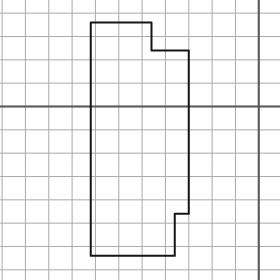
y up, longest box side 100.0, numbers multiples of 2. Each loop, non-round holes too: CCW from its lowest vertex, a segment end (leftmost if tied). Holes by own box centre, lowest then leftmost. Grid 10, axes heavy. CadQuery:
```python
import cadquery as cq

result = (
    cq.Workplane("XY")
    .moveTo(-72.0, -64.0)
    .lineTo(-36.0, -64.0)
    .lineTo(-36.0, -46.0)
    .lineTo(-30.0, -46.0)
    .lineTo(-30.0, 24.0)
    .lineTo(-46.0, 24.0)
    .lineTo(-46.0, 36.0)
    .lineTo(-72.0, 36.0)
    .close()
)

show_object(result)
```